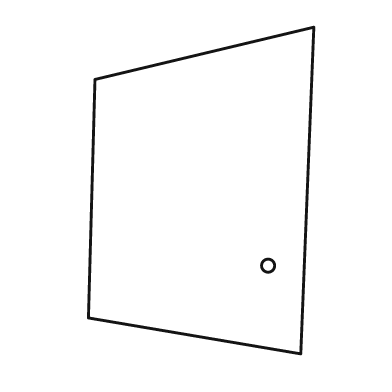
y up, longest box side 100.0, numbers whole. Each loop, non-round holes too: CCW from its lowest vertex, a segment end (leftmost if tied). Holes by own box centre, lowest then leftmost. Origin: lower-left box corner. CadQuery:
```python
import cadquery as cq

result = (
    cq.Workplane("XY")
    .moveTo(65.0, 0.0)
    .lineTo(69.0, 100.0)
    .lineTo(2.0, 84.0)
    .lineTo(0.0, 11.0)
    .close()
    .moveTo(55.0, 27.0)
    .circle(2.0)
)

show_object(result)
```